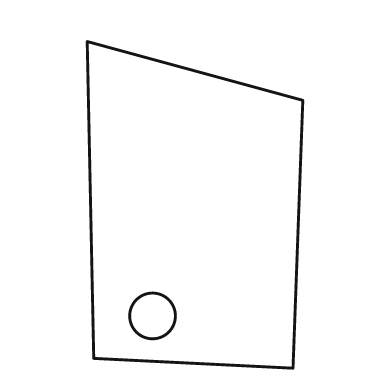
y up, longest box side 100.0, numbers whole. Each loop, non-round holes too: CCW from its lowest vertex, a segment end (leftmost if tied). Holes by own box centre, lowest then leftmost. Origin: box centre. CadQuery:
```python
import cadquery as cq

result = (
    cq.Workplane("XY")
    .moveTo(30.0, -50.0)
    .lineTo(33.0, 32.0)
    .lineTo(-33.0, 50.0)
    .lineTo(-31.0, -47.0)
    .close()
    .moveTo(-13.0, -34.0)
    .circle(7.0)
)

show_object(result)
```